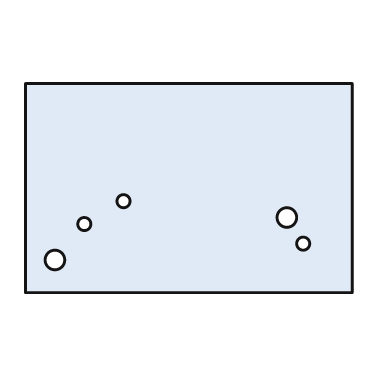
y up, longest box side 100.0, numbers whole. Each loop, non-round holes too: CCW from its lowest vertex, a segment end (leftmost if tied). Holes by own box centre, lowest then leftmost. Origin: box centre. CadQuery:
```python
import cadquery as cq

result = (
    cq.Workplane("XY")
    .moveTo(-50.0, -32.0)
    .lineTo(50.0, -32.0)
    .lineTo(50.0, 32.0)
    .lineTo(-50.0, 32.0)
    .close()
    .moveTo(-41.0, -22.0)
    .circle(3.0)
    .moveTo(35.0, -17.0)
    .circle(2.0)
    .moveTo(-32.0, -11.0)
    .circle(2.0)
    .moveTo(30.0, -9.0)
    .circle(3.0)
    .moveTo(-20.0, -4.0)
    .circle(2.0)
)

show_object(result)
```